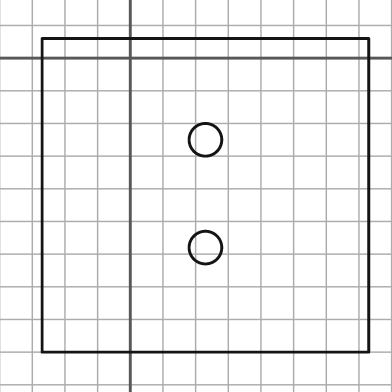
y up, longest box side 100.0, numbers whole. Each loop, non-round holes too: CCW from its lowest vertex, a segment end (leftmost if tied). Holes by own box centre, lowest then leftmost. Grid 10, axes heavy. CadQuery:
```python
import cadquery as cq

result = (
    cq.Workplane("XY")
    .moveTo(-27.0, -90.0)
    .lineTo(73.0, -90.0)
    .lineTo(73.0, 6.0)
    .lineTo(-27.0, 6.0)
    .close()
    .moveTo(23.0, -58.0)
    .circle(5.0)
    .moveTo(23.0, -25.0)
    .circle(5.0)
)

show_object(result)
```